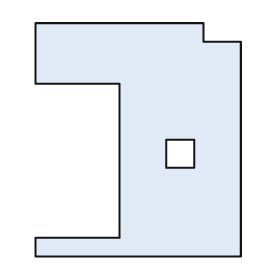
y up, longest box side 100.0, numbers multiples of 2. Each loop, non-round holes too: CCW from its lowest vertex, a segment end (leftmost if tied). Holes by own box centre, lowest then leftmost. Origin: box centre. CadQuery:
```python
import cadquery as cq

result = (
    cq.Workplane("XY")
    .moveTo(-44.0, -50.0)
    .lineTo(44.0, -50.0)
    .lineTo(44.0, 42.0)
    .lineTo(28.0, 42.0)
    .lineTo(28.0, 50.0)
    .lineTo(-44.0, 50.0)
    .lineTo(-44.0, 24.0)
    .lineTo(-8.0, 24.0)
    .lineTo(-8.0, -42.0)
    .lineTo(-44.0, -42.0)
    .close()
    .moveTo(12.0, -12.0)
    .lineTo(24.0, -12.0)
    .lineTo(24.0, 0.0)
    .lineTo(12.0, 0.0)
    .close()
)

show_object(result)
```